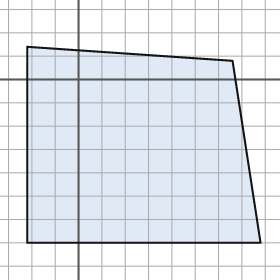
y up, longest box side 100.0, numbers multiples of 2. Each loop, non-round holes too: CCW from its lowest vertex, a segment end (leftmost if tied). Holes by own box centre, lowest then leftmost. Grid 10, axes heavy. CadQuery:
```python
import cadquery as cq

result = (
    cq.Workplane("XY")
    .moveTo(-22.0, -70.0)
    .lineTo(78.0, -70.0)
    .lineTo(66.0, 8.0)
    .lineTo(-22.0, 14.0)
    .close()
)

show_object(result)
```